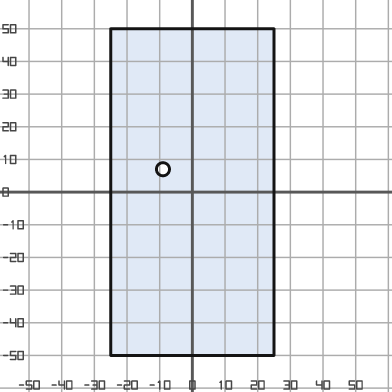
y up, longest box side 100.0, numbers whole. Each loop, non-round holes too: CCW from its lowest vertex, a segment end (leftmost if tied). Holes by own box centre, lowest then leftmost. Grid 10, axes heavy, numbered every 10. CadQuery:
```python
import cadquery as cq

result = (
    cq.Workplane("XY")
    .moveTo(-25.0, -50.0)
    .lineTo(25.0, -50.0)
    .lineTo(25.0, 50.0)
    .lineTo(-25.0, 50.0)
    .close()
    .moveTo(-9.0, 7.0)
    .circle(2.0)
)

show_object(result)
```